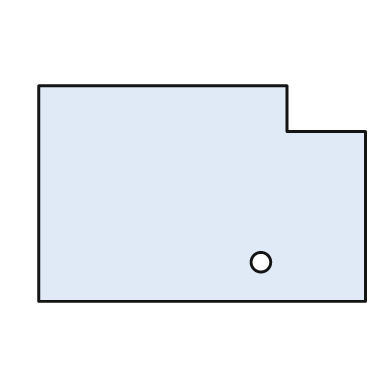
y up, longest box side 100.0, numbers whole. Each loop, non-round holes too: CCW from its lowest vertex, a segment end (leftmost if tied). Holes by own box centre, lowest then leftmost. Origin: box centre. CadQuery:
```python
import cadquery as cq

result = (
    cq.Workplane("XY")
    .moveTo(-50.0, -33.0)
    .lineTo(50.0, -33.0)
    .lineTo(50.0, 19.0)
    .lineTo(26.0, 19.0)
    .lineTo(26.0, 33.0)
    .lineTo(-50.0, 33.0)
    .close()
    .moveTo(18.0, -21.0)
    .circle(3.0)
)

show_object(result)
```